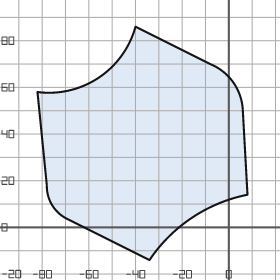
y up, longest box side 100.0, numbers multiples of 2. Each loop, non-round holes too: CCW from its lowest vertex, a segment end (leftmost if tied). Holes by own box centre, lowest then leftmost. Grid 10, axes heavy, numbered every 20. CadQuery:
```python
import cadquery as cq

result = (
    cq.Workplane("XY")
    .moveTo(-34.0, -14.0)
    .threePointArc((-16.0, 4.0), (8.0, 14.0))
    .lineTo(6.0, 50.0)
    .threePointArc((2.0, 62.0), (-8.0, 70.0))
    .lineTo(-40.0, 86.0)
    .threePointArc((-56.0, 64.0), (-82.0, 58.0))
    .lineTo(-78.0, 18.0)
    .threePointArc((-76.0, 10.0), (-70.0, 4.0))
    .close()
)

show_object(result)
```